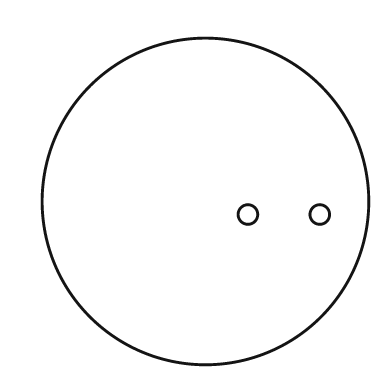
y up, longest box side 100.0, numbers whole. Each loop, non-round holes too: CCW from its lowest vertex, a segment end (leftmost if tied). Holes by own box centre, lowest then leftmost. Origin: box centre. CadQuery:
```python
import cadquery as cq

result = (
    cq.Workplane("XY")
    .moveTo(0.0, 0.0)
    .circle(50.0)
    .moveTo(13.0, -4.0)
    .circle(3.0)
    .moveTo(35.0, -4.0)
    .circle(3.0)
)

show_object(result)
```